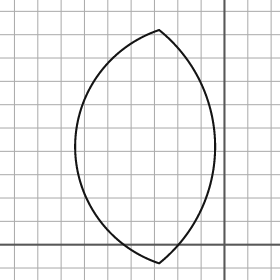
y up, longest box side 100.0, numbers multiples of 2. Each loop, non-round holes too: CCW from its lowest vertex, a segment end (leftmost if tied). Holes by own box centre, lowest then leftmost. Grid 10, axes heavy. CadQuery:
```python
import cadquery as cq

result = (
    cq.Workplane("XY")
    .moveTo(-28.0, -8.0)
    .threePointArc((-4.0, 42.0), (-28.0, 92.0))
    .threePointArc((-64.0, 42.0), (-28.0, -8.0))
    .close()
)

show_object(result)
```